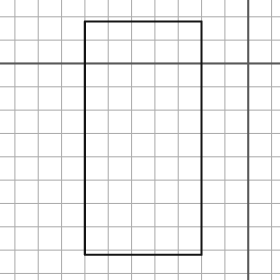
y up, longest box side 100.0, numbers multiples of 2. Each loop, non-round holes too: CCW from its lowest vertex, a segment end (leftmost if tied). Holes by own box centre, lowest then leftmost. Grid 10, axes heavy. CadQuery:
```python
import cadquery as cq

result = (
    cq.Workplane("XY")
    .moveTo(-70.0, -82.0)
    .lineTo(-20.0, -82.0)
    .lineTo(-20.0, 18.0)
    .lineTo(-70.0, 18.0)
    .close()
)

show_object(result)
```